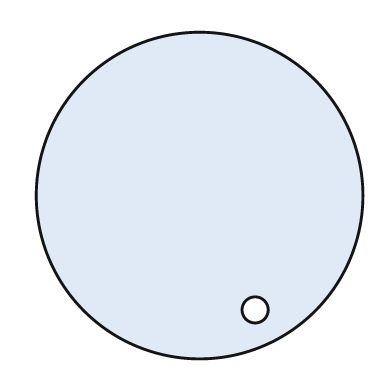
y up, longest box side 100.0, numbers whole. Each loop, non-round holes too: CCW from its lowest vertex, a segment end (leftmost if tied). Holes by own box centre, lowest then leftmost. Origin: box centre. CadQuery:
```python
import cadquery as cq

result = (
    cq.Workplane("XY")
    .moveTo(0.0, 0.0)
    .circle(50.0)
    .moveTo(17.0, -35.0)
    .circle(4.0)
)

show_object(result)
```